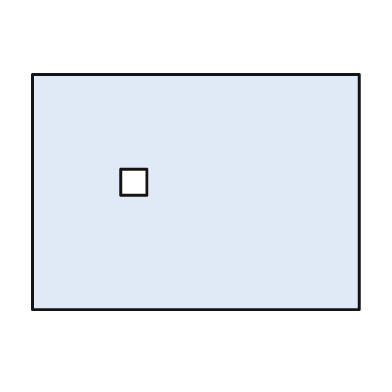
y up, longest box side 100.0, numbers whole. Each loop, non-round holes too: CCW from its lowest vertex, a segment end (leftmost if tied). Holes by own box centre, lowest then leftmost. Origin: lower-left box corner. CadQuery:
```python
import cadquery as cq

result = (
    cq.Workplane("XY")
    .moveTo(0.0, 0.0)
    .lineTo(100.0, 0.0)
    .lineTo(100.0, 72.0)
    .lineTo(0.0, 72.0)
    .close()
    .moveTo(27.0, 35.0)
    .lineTo(35.0, 35.0)
    .lineTo(35.0, 43.0)
    .lineTo(27.0, 43.0)
    .close()
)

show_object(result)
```